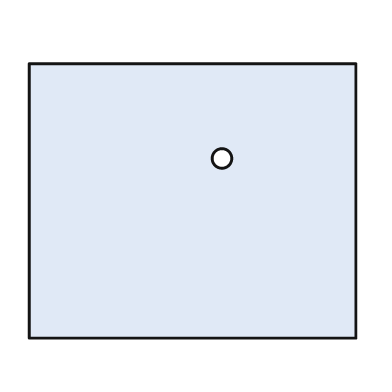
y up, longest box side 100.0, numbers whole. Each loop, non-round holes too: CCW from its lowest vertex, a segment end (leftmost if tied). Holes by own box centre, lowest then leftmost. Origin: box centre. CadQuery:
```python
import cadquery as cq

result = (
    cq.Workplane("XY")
    .moveTo(-50.0, -42.0)
    .lineTo(50.0, -42.0)
    .lineTo(50.0, 42.0)
    .lineTo(-50.0, 42.0)
    .close()
    .moveTo(9.0, 13.0)
    .circle(3.0)
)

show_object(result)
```